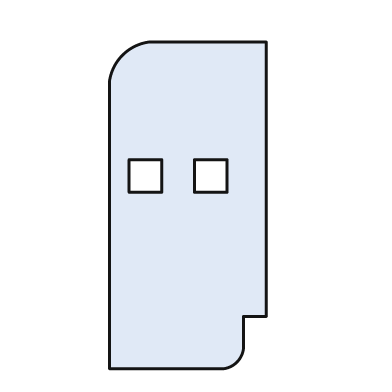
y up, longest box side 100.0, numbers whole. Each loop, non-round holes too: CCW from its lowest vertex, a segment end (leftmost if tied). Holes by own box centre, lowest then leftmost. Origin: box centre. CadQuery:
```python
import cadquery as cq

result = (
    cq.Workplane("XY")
    .moveTo(-24.0, -50.0)
    .lineTo(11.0, -50.0)
    .threePointArc((15.0, -48.0), (17.0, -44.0))
    .lineTo(17.0, -34.0)
    .lineTo(24.0, -34.0)
    .lineTo(24.0, 50.0)
    .lineTo(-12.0, 50.0)
    .threePointArc((-20.0, 46.0), (-24.0, 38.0))
    .close()
    .moveTo(-18.0, 4.0)
    .lineTo(-8.0, 4.0)
    .lineTo(-8.0, 14.0)
    .lineTo(-18.0, 14.0)
    .close()
    .moveTo(2.0, 4.0)
    .lineTo(12.0, 4.0)
    .lineTo(12.0, 14.0)
    .lineTo(2.0, 14.0)
    .close()
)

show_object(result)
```